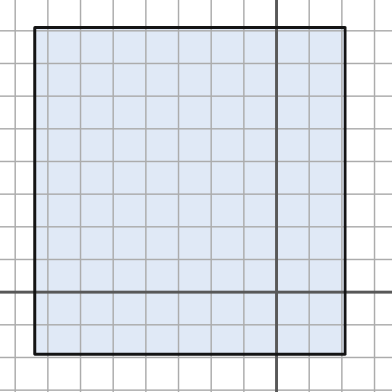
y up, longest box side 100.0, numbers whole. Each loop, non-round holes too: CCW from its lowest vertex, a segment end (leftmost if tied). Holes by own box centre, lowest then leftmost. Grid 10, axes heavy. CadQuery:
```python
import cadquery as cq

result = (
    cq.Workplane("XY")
    .moveTo(-74.0, -19.0)
    .lineTo(21.0, -19.0)
    .lineTo(21.0, 81.0)
    .lineTo(-74.0, 81.0)
    .close()
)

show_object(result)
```